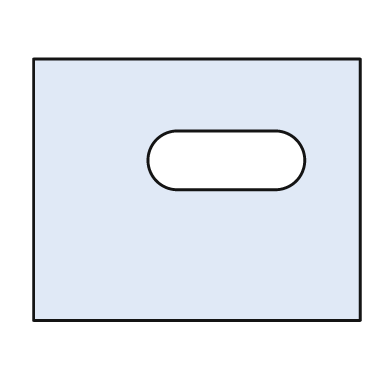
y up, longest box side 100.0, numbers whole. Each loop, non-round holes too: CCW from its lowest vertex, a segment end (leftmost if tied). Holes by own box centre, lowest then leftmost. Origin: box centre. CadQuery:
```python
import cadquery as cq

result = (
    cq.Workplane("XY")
    .moveTo(-50.0, -40.0)
    .lineTo(50.0, -40.0)
    .lineTo(50.0, 40.0)
    .lineTo(-50.0, 40.0)
    .close()
    .moveTo(-6.0, 0.0)
    .lineTo(24.0, 0.0)
    .threePointArc((33.0, 9.0), (24.0, 18.0))
    .lineTo(-6.0, 18.0)
    .threePointArc((-15.0, 9.0), (-6.0, 0.0))
    .close()
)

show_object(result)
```